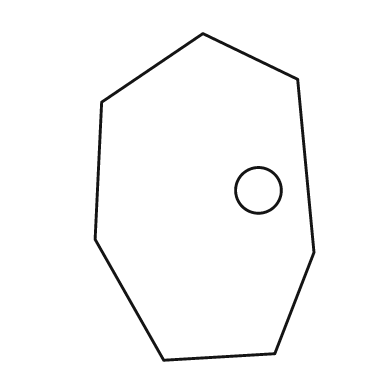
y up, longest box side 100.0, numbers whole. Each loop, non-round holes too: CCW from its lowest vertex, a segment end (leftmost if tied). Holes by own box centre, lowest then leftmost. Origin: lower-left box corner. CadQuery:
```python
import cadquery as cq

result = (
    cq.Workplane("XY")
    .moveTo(21.0, 0.0)
    .lineTo(55.0, 2.0)
    .lineTo(67.0, 33.0)
    .lineTo(62.0, 86.0)
    .lineTo(33.0, 100.0)
    .lineTo(2.0, 79.0)
    .lineTo(0.0, 37.0)
    .close()
    .moveTo(50.0, 52.0)
    .circle(7.0)
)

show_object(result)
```